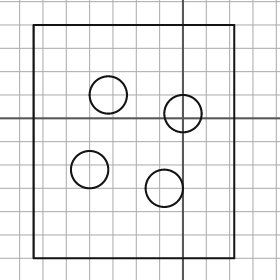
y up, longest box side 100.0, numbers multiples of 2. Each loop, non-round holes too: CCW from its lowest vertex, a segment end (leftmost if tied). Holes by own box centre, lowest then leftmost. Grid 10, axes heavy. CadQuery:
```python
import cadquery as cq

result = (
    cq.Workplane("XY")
    .moveTo(-64.0, -60.0)
    .lineTo(22.0, -60.0)
    .lineTo(22.0, 40.0)
    .lineTo(-64.0, 40.0)
    .close()
    .moveTo(-8.0, -30.0)
    .circle(8.0)
    .moveTo(-40.0, -22.0)
    .circle(8.0)
    .moveTo(0.0, 2.0)
    .circle(8.0)
    .moveTo(-32.0, 10.0)
    .circle(8.0)
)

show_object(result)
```